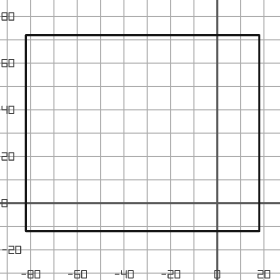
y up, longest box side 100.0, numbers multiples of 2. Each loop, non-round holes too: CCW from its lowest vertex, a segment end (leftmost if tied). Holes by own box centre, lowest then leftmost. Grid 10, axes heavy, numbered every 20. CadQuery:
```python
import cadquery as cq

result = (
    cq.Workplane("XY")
    .moveTo(-82.0, -12.0)
    .lineTo(18.0, -12.0)
    .lineTo(18.0, 72.0)
    .lineTo(-82.0, 72.0)
    .close()
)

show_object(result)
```